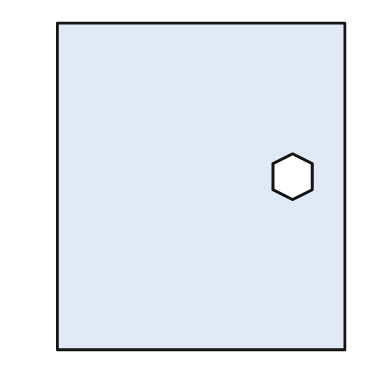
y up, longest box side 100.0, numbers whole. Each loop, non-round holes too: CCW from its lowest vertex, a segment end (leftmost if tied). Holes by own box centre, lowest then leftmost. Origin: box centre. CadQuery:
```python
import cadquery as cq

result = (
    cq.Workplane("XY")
    .moveTo(-44.0, -50.0)
    .lineTo(44.0, -50.0)
    .lineTo(44.0, 50.0)
    .lineTo(-44.0, 50.0)
    .close()
    .moveTo(28.0, -4.0)
    .lineTo(34.0, -1.0)
    .lineTo(34.0, 7.0)
    .lineTo(28.0, 10.0)
    .lineTo(22.0, 7.0)
    .lineTo(22.0, -1.0)
    .close()
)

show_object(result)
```